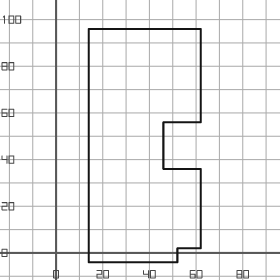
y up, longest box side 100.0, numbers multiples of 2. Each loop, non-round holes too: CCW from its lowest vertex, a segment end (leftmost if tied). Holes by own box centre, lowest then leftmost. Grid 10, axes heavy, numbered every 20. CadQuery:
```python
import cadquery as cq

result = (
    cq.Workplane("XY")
    .moveTo(14.0, -4.0)
    .lineTo(52.0, -4.0)
    .lineTo(52.0, 2.0)
    .lineTo(62.0, 2.0)
    .lineTo(62.0, 36.0)
    .lineTo(46.0, 36.0)
    .lineTo(46.0, 56.0)
    .lineTo(62.0, 56.0)
    .lineTo(62.0, 96.0)
    .lineTo(14.0, 96.0)
    .close()
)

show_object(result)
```